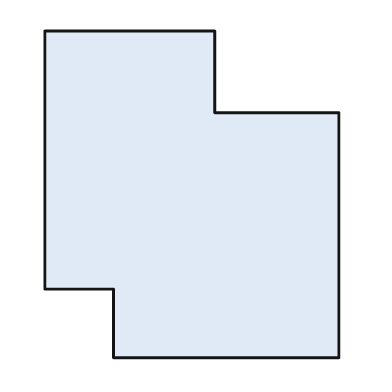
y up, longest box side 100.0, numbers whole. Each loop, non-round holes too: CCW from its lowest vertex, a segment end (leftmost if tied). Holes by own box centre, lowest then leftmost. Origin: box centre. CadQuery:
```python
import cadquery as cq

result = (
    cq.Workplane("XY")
    .moveTo(-24.0, -50.0)
    .lineTo(45.0, -50.0)
    .lineTo(45.0, 25.0)
    .lineTo(7.0, 25.0)
    .lineTo(7.0, 50.0)
    .lineTo(-45.0, 50.0)
    .lineTo(-45.0, -29.0)
    .lineTo(-24.0, -29.0)
    .close()
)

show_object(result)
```